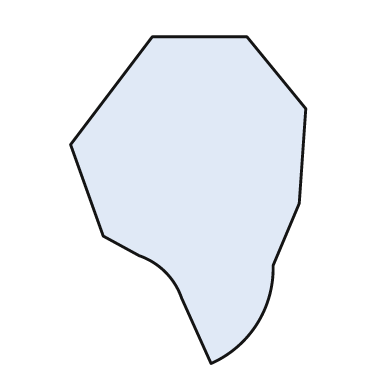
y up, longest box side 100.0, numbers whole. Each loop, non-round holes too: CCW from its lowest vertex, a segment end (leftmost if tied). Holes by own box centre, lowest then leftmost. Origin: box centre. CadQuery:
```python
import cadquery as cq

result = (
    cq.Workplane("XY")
    .moveTo(7.0, -50.0)
    .threePointArc((21.0, -38.0), (26.0, -20.0))
    .lineTo(34.0, -1.0)
    .lineTo(36.0, 28.0)
    .lineTo(18.0, 50.0)
    .lineTo(-11.0, 50.0)
    .lineTo(-36.0, 17.0)
    .lineTo(-26.0, -11.0)
    .lineTo(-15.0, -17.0)
    .threePointArc((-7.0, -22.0), (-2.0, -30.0))
    .close()
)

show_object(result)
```